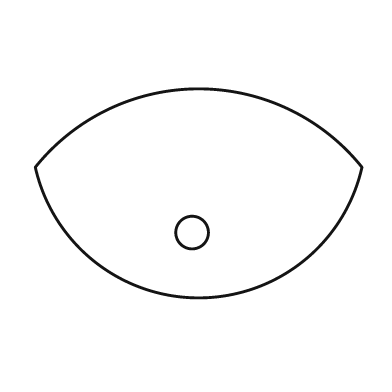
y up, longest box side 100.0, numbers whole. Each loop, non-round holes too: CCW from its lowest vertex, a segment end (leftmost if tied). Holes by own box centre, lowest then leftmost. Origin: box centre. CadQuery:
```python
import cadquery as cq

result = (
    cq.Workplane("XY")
    .moveTo(-50.0, 8.0)
    .threePointArc((0.0, -32.0), (50.0, 8.0))
    .threePointArc((0.0, 32.0), (-50.0, 8.0))
    .close()
    .moveTo(-2.0, -12.0)
    .circle(5.0)
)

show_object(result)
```